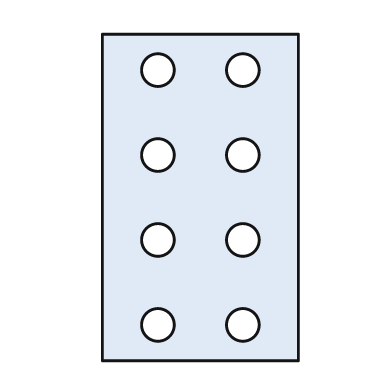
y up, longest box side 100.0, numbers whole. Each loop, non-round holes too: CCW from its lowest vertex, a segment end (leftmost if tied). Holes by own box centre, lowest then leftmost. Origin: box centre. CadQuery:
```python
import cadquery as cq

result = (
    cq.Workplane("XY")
    .moveTo(-30.0, -50.0)
    .lineTo(30.0, -50.0)
    .lineTo(30.0, 50.0)
    .lineTo(-30.0, 50.0)
    .close()
    .moveTo(-13.0, -39.0)
    .circle(5.0)
    .moveTo(13.0, -39.0)
    .circle(5.0)
    .moveTo(-13.0, -13.0)
    .circle(5.0)
    .moveTo(13.0, -13.0)
    .circle(5.0)
    .moveTo(-13.0, 13.0)
    .circle(5.0)
    .moveTo(13.0, 13.0)
    .circle(5.0)
    .moveTo(-13.0, 39.0)
    .circle(5.0)
    .moveTo(13.0, 39.0)
    .circle(5.0)
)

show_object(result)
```